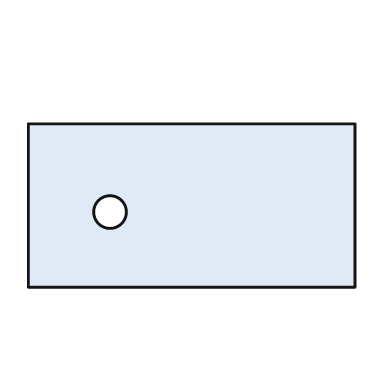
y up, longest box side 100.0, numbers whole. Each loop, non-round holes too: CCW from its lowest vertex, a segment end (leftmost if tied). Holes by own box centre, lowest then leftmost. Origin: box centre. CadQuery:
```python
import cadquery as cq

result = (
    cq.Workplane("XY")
    .moveTo(-50.0, -25.0)
    .lineTo(50.0, -25.0)
    .lineTo(50.0, 25.0)
    .lineTo(-50.0, 25.0)
    .close()
    .moveTo(-25.0, -2.0)
    .circle(5.0)
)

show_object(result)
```